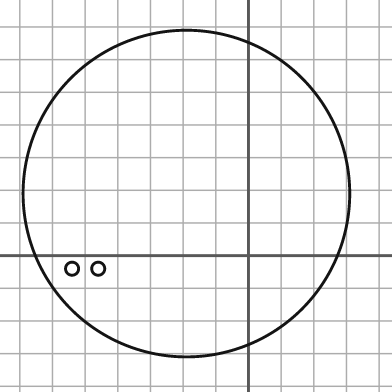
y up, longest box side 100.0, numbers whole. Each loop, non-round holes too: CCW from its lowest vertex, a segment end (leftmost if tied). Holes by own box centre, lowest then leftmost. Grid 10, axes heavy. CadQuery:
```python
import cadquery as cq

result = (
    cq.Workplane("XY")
    .moveTo(-19.0, 19.0)
    .circle(50.0)
    .moveTo(-54.0, -4.0)
    .circle(2.0)
    .moveTo(-46.0, -4.0)
    .circle(2.0)
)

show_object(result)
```